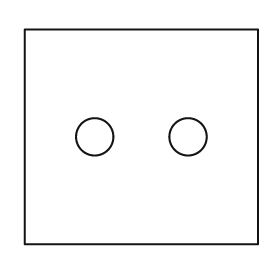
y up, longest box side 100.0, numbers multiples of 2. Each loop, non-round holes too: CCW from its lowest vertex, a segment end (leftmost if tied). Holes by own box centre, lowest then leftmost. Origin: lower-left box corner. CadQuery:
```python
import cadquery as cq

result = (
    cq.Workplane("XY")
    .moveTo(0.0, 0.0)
    .lineTo(100.0, 0.0)
    .lineTo(100.0, 92.0)
    .lineTo(0.0, 92.0)
    .close()
    .moveTo(30.0, 46.0)
    .circle(8.0)
    .moveTo(70.0, 46.0)
    .circle(8.0)
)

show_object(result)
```